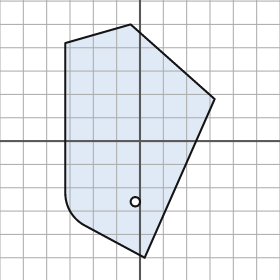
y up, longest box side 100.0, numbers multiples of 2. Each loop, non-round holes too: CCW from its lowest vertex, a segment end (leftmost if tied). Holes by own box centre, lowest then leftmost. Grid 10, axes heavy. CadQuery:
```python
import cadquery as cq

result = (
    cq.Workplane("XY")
    .moveTo(2.0, -50.0)
    .lineTo(32.0, 18.0)
    .lineTo(-4.0, 50.0)
    .lineTo(-32.0, 42.0)
    .lineTo(-32.0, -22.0)
    .threePointArc((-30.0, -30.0), (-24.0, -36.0))
    .close()
    .moveTo(-2.0, -26.0)
    .circle(2.0)
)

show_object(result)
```